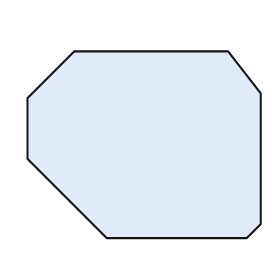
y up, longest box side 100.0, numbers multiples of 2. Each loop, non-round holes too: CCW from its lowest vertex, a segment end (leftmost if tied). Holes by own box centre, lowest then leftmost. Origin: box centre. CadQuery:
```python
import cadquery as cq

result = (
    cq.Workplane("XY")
    .moveTo(-16.0, -40.0)
    .lineTo(44.0, -40.0)
    .lineTo(50.0, -34.0)
    .lineTo(50.0, 22.0)
    .lineTo(36.0, 40.0)
    .lineTo(-30.0, 40.0)
    .lineTo(-50.0, 20.0)
    .lineTo(-50.0, -6.0)
    .close()
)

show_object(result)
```